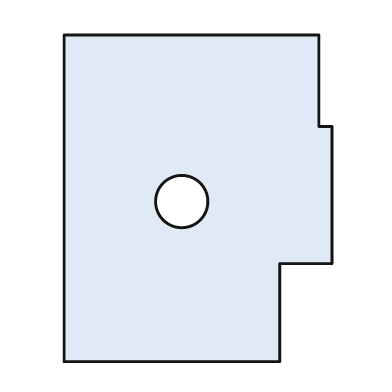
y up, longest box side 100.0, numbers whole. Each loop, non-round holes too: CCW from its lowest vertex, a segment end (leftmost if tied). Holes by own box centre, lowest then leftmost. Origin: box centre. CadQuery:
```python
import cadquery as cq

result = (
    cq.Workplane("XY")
    .moveTo(-41.0, -50.0)
    .lineTo(25.0, -50.0)
    .lineTo(25.0, -20.0)
    .lineTo(41.0, -20.0)
    .lineTo(41.0, 22.0)
    .lineTo(37.0, 22.0)
    .lineTo(37.0, 50.0)
    .lineTo(-41.0, 50.0)
    .close()
    .moveTo(-5.0, -1.0)
    .circle(8.0)
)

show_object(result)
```